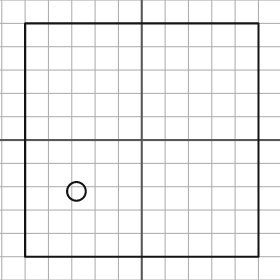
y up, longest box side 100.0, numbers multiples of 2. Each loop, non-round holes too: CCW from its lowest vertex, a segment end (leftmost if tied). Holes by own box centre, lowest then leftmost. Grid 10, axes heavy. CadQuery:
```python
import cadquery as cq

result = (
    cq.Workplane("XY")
    .moveTo(-50.0, -50.0)
    .lineTo(50.0, -50.0)
    .lineTo(50.0, 50.0)
    .lineTo(-50.0, 50.0)
    .close()
    .moveTo(-28.0, -22.0)
    .circle(4.0)
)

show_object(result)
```